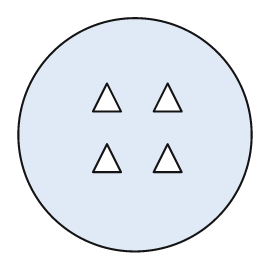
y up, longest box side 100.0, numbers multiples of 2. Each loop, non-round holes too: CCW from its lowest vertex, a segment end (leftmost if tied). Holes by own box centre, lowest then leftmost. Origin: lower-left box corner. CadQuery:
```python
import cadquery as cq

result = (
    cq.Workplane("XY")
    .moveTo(50.0, 50.0)
    .circle(50.0)
    .moveTo(32.0, 34.0)
    .lineTo(44.0, 34.0)
    .lineTo(38.0, 46.0)
    .close()
    .moveTo(58.0, 34.0)
    .lineTo(70.0, 34.0)
    .lineTo(64.0, 46.0)
    .close()
    .moveTo(32.0, 60.0)
    .lineTo(44.0, 60.0)
    .lineTo(38.0, 72.0)
    .close()
    .moveTo(58.0, 60.0)
    .lineTo(70.0, 60.0)
    .lineTo(64.0, 72.0)
    .close()
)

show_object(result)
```